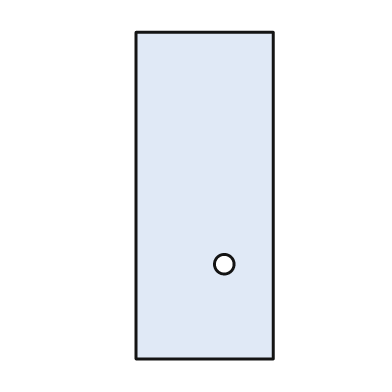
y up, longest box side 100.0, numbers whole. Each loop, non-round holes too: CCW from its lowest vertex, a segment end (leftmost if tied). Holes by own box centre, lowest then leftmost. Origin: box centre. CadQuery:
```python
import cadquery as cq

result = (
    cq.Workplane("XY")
    .moveTo(-21.0, -50.0)
    .lineTo(21.0, -50.0)
    .lineTo(21.0, 50.0)
    .lineTo(-21.0, 50.0)
    .close()
    .moveTo(6.0, -21.0)
    .circle(3.0)
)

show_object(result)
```